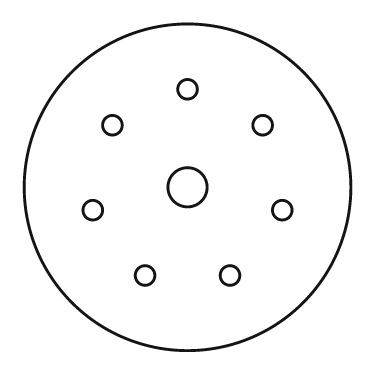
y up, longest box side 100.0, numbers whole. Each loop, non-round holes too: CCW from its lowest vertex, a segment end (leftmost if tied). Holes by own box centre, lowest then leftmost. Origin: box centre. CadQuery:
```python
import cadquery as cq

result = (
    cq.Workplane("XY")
    .moveTo(0.0, 0.0)
    .circle(50.0)
    .moveTo(-13.0, -27.0)
    .circle(3.0)
    .moveTo(13.0, -27.0)
    .circle(3.0)
    .moveTo(-29.0, -7.0)
    .circle(3.0)
    .moveTo(29.0, -7.0)
    .circle(3.0)
    .moveTo(0.0, 0.0)
    .circle(6.0)
    .moveTo(-23.0, 19.0)
    .circle(3.0)
    .moveTo(23.0, 19.0)
    .circle(3.0)
    .moveTo(0.0, 30.0)
    .circle(3.0)
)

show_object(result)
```